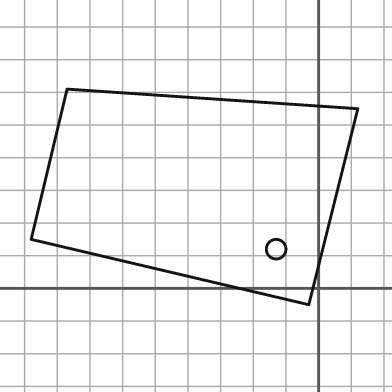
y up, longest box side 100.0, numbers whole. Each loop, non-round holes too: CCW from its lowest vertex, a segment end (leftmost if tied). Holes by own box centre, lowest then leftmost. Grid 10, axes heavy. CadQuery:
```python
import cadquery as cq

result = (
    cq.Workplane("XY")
    .moveTo(-3.0, -5.0)
    .lineTo(12.0, 55.0)
    .lineTo(-77.0, 61.0)
    .lineTo(-88.0, 15.0)
    .close()
    .moveTo(-13.0, 12.0)
    .circle(3.0)
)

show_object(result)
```